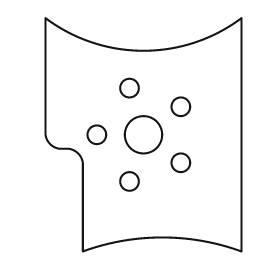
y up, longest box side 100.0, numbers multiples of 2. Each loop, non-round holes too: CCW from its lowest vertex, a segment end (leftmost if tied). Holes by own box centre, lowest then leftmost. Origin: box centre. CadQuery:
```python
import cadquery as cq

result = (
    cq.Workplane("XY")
    .moveTo(-26.0, -50.0)
    .threePointArc((8.0, -44.0), (42.0, -50.0))
    .lineTo(42.0, 50.0)
    .threePointArc((0.0, 36.0), (-42.0, 50.0))
    .lineTo(-42.0, 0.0)
    .threePointArc((-40.0, -4.0), (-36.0, -6.0))
    .lineTo(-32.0, -6.0)
    .threePointArc((-28.0, -8.0), (-26.0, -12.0))
    .close()
    .moveTo(-6.0, -20.0)
    .circle(4.0)
    .moveTo(16.0, -12.0)
    .circle(4.0)
    .moveTo(-20.0, 0.0)
    .circle(4.0)
    .moveTo(0.0, 0.0)
    .circle(8.0)
    .moveTo(16.0, 12.0)
    .circle(4.0)
    .moveTo(-6.0, 20.0)
    .circle(4.0)
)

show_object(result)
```